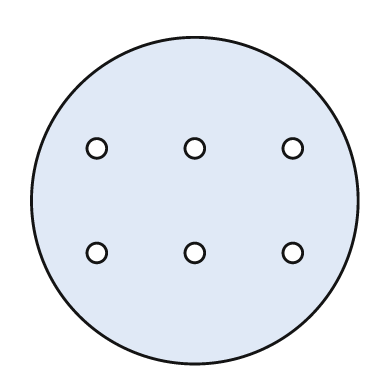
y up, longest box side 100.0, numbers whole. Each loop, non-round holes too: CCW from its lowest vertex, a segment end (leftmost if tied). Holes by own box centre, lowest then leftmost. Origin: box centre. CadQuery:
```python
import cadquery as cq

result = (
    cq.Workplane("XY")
    .moveTo(0.0, 0.0)
    .circle(50.0)
    .moveTo(-30.0, -16.0)
    .circle(3.0)
    .moveTo(0.0, -16.0)
    .circle(3.0)
    .moveTo(30.0, -16.0)
    .circle(3.0)
    .moveTo(-30.0, 16.0)
    .circle(3.0)
    .moveTo(0.0, 16.0)
    .circle(3.0)
    .moveTo(30.0, 16.0)
    .circle(3.0)
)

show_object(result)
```